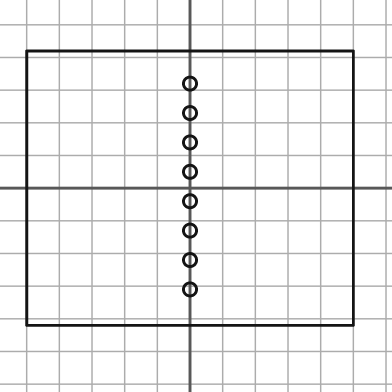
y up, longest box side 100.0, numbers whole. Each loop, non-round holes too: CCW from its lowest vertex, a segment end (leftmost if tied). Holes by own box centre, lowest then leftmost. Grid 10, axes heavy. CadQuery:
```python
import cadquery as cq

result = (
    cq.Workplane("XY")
    .moveTo(-50.0, -42.0)
    .lineTo(50.0, -42.0)
    .lineTo(50.0, 42.0)
    .lineTo(-50.0, 42.0)
    .close()
    .moveTo(0.0, -31.0)
    .circle(2.0)
    .moveTo(0.0, -22.0)
    .circle(2.0)
    .moveTo(0.0, -13.0)
    .circle(2.0)
    .moveTo(0.0, -4.0)
    .circle(2.0)
    .moveTo(0.0, 5.0)
    .circle(2.0)
    .moveTo(0.0, 14.0)
    .circle(2.0)
    .moveTo(0.0, 23.0)
    .circle(2.0)
    .moveTo(0.0, 32.0)
    .circle(2.0)
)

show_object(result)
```